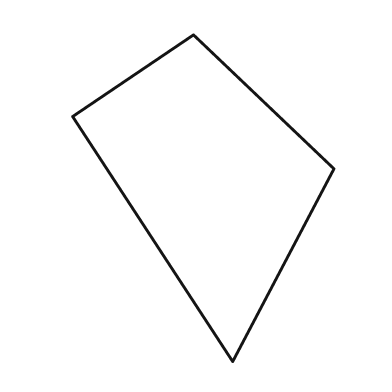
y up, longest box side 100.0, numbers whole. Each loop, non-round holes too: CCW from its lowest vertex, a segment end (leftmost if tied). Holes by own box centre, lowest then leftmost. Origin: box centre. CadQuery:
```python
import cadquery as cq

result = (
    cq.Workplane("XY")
    .moveTo(9.0, -50.0)
    .lineTo(40.0, 9.0)
    .lineTo(-3.0, 50.0)
    .lineTo(-40.0, 25.0)
    .close()
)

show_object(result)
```